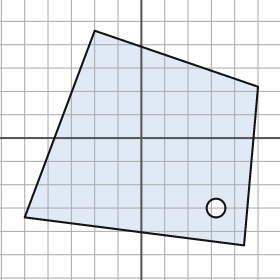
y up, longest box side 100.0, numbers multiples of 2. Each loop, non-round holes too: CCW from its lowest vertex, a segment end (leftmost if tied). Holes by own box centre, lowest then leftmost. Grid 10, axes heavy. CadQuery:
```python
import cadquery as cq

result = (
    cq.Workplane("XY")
    .moveTo(44.0, -46.0)
    .lineTo(50.0, 22.0)
    .lineTo(-20.0, 46.0)
    .lineTo(-50.0, -34.0)
    .close()
    .moveTo(32.0, -30.0)
    .circle(4.0)
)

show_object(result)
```